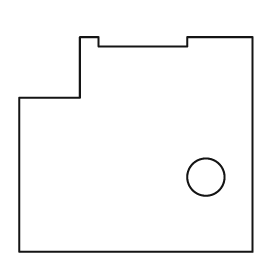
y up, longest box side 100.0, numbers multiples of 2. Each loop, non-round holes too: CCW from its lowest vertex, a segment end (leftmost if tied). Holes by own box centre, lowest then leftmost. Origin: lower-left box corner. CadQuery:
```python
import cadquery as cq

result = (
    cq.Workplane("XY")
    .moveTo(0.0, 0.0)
    .lineTo(100.0, 0.0)
    .lineTo(100.0, 92.0)
    .lineTo(72.0, 92.0)
    .lineTo(72.0, 88.0)
    .lineTo(34.0, 88.0)
    .lineTo(34.0, 92.0)
    .lineTo(26.0, 92.0)
    .lineTo(26.0, 66.0)
    .lineTo(0.0, 66.0)
    .close()
    .moveTo(80.0, 32.0)
    .circle(8.0)
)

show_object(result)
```